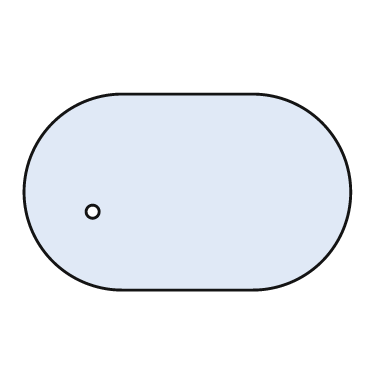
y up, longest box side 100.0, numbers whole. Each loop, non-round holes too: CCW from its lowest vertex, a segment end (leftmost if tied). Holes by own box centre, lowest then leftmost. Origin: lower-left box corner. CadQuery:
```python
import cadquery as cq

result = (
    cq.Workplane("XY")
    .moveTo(30.0, 0.0)
    .lineTo(70.0, 0.0)
    .threePointArc((100.0, 30.0), (70.0, 60.0))
    .lineTo(30.0, 60.0)
    .threePointArc((0.0, 30.0), (30.0, 0.0))
    .close()
    .moveTo(21.0, 24.0)
    .circle(2.0)
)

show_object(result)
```